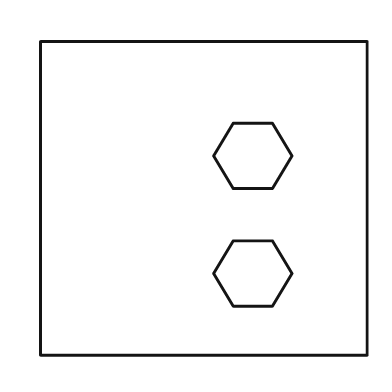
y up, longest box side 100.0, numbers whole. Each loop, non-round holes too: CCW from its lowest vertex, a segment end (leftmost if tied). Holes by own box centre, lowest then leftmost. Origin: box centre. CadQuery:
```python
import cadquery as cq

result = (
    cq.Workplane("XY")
    .moveTo(-50.0, -48.0)
    .lineTo(50.0, -48.0)
    .lineTo(50.0, 48.0)
    .lineTo(-50.0, 48.0)
    .close()
    .moveTo(9.0, -33.0)
    .lineTo(21.0, -33.0)
    .lineTo(27.0, -23.0)
    .lineTo(21.0, -13.0)
    .lineTo(9.0, -13.0)
    .lineTo(3.0, -23.0)
    .close()
    .moveTo(9.0, 3.0)
    .lineTo(21.0, 3.0)
    .lineTo(27.0, 13.0)
    .lineTo(21.0, 23.0)
    .lineTo(9.0, 23.0)
    .lineTo(3.0, 13.0)
    .close()
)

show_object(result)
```